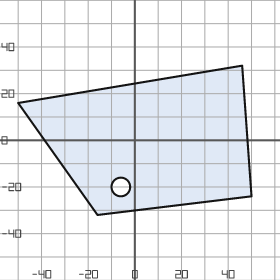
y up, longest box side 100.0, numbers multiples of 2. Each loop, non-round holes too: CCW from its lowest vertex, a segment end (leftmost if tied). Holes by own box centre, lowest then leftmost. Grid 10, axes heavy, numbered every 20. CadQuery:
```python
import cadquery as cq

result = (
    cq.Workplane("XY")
    .moveTo(-16.0, -32.0)
    .lineTo(50.0, -24.0)
    .lineTo(46.0, 32.0)
    .lineTo(-50.0, 16.0)
    .close()
    .moveTo(-6.0, -20.0)
    .circle(4.0)
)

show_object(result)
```